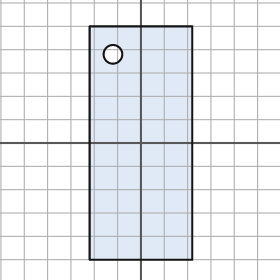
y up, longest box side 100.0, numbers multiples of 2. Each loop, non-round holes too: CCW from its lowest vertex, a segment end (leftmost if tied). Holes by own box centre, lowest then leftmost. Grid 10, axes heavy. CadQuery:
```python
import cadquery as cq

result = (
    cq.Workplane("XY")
    .moveTo(-22.0, -50.0)
    .lineTo(22.0, -50.0)
    .lineTo(22.0, 50.0)
    .lineTo(-22.0, 50.0)
    .close()
    .moveTo(-12.0, 38.0)
    .circle(4.0)
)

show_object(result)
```